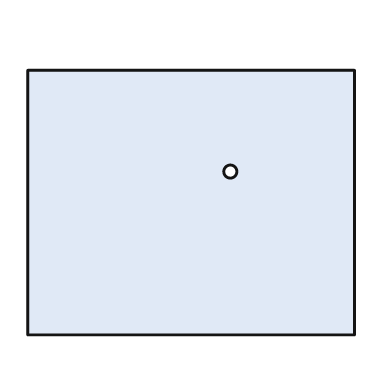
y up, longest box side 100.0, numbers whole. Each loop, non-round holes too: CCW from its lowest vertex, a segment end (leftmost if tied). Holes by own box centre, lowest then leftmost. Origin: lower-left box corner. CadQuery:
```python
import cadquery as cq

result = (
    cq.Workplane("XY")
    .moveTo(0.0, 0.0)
    .lineTo(100.0, 0.0)
    .lineTo(100.0, 81.0)
    .lineTo(0.0, 81.0)
    .close()
    .moveTo(62.0, 50.0)
    .circle(2.0)
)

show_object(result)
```